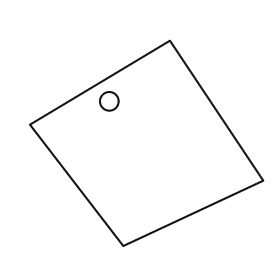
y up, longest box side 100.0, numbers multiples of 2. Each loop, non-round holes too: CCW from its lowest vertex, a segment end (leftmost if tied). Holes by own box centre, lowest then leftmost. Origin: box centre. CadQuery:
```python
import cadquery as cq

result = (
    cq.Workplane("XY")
    .moveTo(-10.0, -44.0)
    .lineTo(50.0, -16.0)
    .lineTo(10.0, 44.0)
    .lineTo(-50.0, 8.0)
    .close()
    .moveTo(-16.0, 18.0)
    .circle(4.0)
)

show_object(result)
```